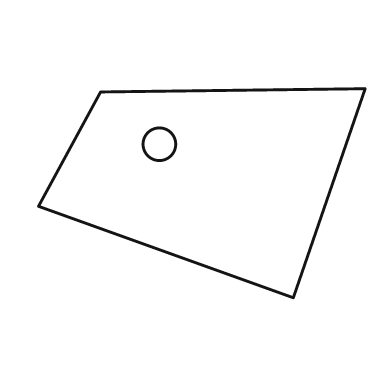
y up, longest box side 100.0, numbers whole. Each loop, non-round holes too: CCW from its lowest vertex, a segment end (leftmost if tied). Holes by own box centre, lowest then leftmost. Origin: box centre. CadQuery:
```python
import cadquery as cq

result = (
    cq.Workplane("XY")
    .moveTo(28.0, -32.0)
    .lineTo(50.0, 32.0)
    .lineTo(-31.0, 31.0)
    .lineTo(-50.0, -4.0)
    .close()
    .moveTo(-13.0, 15.0)
    .circle(5.0)
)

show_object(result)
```